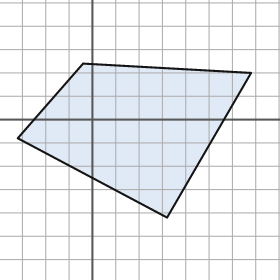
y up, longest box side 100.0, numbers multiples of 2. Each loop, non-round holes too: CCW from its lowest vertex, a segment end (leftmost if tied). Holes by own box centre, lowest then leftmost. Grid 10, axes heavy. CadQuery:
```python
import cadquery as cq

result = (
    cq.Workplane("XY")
    .moveTo(32.0, -42.0)
    .lineTo(68.0, 20.0)
    .lineTo(-4.0, 24.0)
    .lineTo(-32.0, -8.0)
    .close()
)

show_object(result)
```